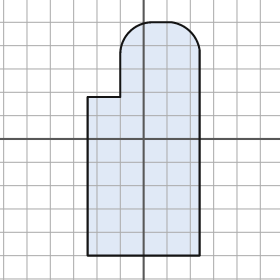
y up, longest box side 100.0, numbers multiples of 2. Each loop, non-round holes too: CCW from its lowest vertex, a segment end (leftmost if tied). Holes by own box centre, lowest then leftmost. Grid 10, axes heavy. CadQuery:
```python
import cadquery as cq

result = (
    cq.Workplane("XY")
    .moveTo(-24.0, -50.0)
    .lineTo(24.0, -50.0)
    .lineTo(24.0, 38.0)
    .threePointArc((20.0, 46.0), (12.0, 50.0))
    .lineTo(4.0, 50.0)
    .threePointArc((-6.0, 46.0), (-10.0, 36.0))
    .lineTo(-10.0, 18.0)
    .lineTo(-24.0, 18.0)
    .close()
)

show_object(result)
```